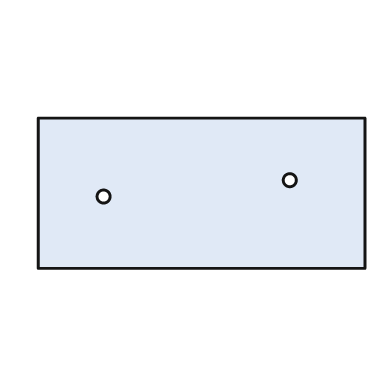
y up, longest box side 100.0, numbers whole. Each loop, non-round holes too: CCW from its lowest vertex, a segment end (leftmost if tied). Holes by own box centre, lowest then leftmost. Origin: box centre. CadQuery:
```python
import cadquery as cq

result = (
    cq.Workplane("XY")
    .moveTo(-50.0, -23.0)
    .lineTo(50.0, -23.0)
    .lineTo(50.0, 23.0)
    .lineTo(-50.0, 23.0)
    .close()
    .moveTo(-30.0, -1.0)
    .circle(2.0)
    .moveTo(27.0, 4.0)
    .circle(2.0)
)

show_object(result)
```